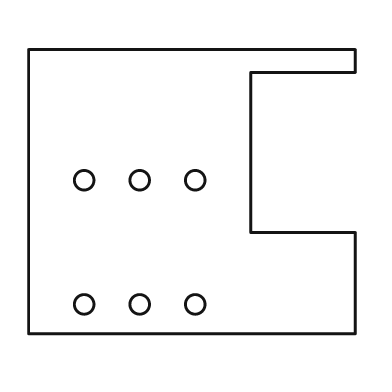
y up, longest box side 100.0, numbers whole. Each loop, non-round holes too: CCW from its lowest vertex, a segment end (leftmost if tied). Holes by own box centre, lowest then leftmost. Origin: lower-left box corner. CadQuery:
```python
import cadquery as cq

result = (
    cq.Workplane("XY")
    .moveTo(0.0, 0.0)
    .lineTo(100.0, 0.0)
    .lineTo(100.0, 31.0)
    .lineTo(68.0, 31.0)
    .lineTo(68.0, 80.0)
    .lineTo(100.0, 80.0)
    .lineTo(100.0, 87.0)
    .lineTo(0.0, 87.0)
    .close()
    .moveTo(17.0, 9.0)
    .circle(3.0)
    .moveTo(34.0, 9.0)
    .circle(3.0)
    .moveTo(51.0, 9.0)
    .circle(3.0)
    .moveTo(17.0, 47.0)
    .circle(3.0)
    .moveTo(34.0, 47.0)
    .circle(3.0)
    .moveTo(51.0, 47.0)
    .circle(3.0)
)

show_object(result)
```